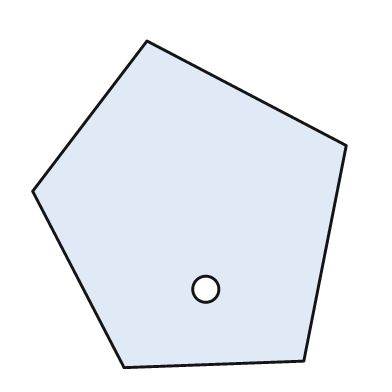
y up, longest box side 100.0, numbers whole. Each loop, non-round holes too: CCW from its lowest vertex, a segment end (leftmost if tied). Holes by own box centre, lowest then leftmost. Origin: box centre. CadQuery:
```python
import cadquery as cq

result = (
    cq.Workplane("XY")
    .moveTo(-20.0, -50.0)
    .lineTo(35.0, -48.0)
    .lineTo(48.0, 18.0)
    .lineTo(-13.0, 50.0)
    .lineTo(-48.0, 4.0)
    .close()
    .moveTo(5.0, -26.0)
    .circle(4.0)
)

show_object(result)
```